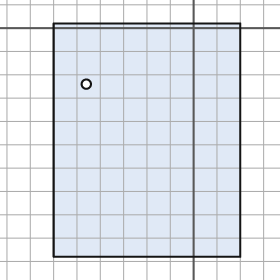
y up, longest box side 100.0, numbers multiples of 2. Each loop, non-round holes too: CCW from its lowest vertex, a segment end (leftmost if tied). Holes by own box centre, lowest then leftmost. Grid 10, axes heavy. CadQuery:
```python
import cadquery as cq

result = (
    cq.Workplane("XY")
    .moveTo(-60.0, -98.0)
    .lineTo(20.0, -98.0)
    .lineTo(20.0, 2.0)
    .lineTo(-60.0, 2.0)
    .close()
    .moveTo(-46.0, -24.0)
    .circle(2.0)
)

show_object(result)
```